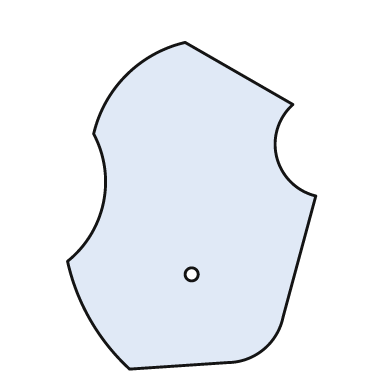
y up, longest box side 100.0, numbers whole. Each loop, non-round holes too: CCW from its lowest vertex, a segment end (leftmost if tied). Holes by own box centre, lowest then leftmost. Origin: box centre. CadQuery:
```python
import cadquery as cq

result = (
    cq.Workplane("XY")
    .moveTo(-19.0, -50.0)
    .lineTo(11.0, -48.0)
    .threePointArc((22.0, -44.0), (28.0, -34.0))
    .lineTo(38.0, 3.0)
    .threePointArc((26.0, 15.0), (31.0, 31.0))
    .lineTo(-2.0, 50.0)
    .threePointArc((-20.0, 40.0), (-30.0, 22.0))
    .threePointArc((-27.0, 1.0), (-38.0, -17.0))
    .threePointArc((-31.0, -35.0), (-19.0, -50.0))
    .close()
    .moveTo(0.0, -21.0)
    .circle(2.0)
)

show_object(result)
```